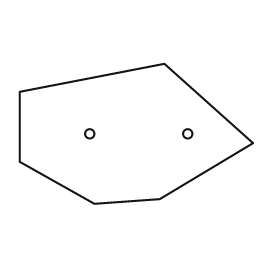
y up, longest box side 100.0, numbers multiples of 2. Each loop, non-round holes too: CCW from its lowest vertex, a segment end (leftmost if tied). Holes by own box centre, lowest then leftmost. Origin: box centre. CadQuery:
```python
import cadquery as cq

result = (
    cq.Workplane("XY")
    .moveTo(-18.0, -30.0)
    .lineTo(10.0, -28.0)
    .lineTo(50.0, -4.0)
    .lineTo(12.0, 30.0)
    .lineTo(-50.0, 18.0)
    .lineTo(-50.0, -12.0)
    .close()
    .moveTo(-20.0, 0.0)
    .circle(2.0)
    .moveTo(22.0, 0.0)
    .circle(2.0)
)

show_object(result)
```